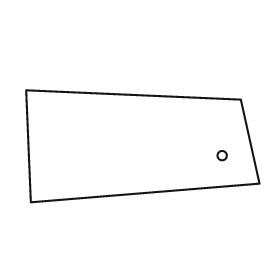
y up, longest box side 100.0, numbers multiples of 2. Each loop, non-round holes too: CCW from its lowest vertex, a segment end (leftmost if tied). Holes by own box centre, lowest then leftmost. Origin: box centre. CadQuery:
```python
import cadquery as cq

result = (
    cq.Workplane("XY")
    .moveTo(-48.0, -24.0)
    .lineTo(50.0, -16.0)
    .lineTo(42.0, 20.0)
    .lineTo(-50.0, 24.0)
    .close()
    .moveTo(34.0, -4.0)
    .circle(2.0)
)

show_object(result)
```